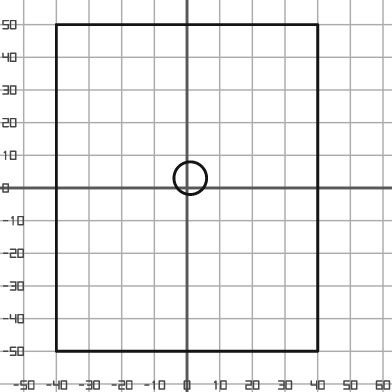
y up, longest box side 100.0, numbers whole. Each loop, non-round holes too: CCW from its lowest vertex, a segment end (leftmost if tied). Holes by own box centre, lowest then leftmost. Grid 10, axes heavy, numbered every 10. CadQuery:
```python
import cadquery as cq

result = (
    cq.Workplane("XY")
    .moveTo(-40.0, -50.0)
    .lineTo(40.0, -50.0)
    .lineTo(40.0, 50.0)
    .lineTo(-40.0, 50.0)
    .close()
    .moveTo(1.0, 3.0)
    .circle(5.0)
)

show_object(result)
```